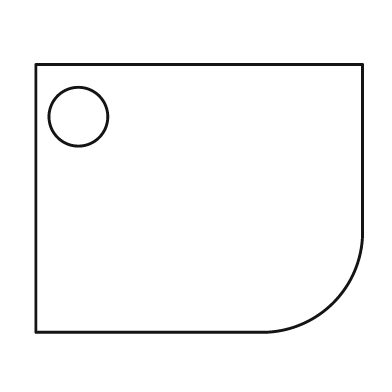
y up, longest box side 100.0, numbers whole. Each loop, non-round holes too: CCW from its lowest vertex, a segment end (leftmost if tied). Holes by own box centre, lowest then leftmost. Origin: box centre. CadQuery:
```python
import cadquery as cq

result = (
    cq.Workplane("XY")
    .moveTo(-50.0, -41.0)
    .lineTo(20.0, -41.0)
    .threePointArc((41.0, -32.0), (50.0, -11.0))
    .lineTo(50.0, 41.0)
    .lineTo(-50.0, 41.0)
    .close()
    .moveTo(-37.0, 25.0)
    .circle(9.0)
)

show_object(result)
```